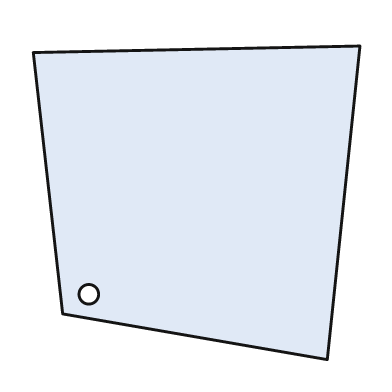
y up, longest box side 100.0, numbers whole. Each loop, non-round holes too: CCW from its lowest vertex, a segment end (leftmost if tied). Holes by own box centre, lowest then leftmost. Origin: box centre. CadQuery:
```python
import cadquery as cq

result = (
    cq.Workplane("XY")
    .moveTo(40.0, -48.0)
    .lineTo(50.0, 48.0)
    .lineTo(-50.0, 46.0)
    .lineTo(-41.0, -34.0)
    .close()
    .moveTo(-33.0, -28.0)
    .circle(3.0)
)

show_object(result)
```